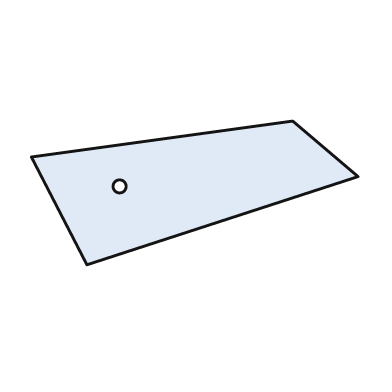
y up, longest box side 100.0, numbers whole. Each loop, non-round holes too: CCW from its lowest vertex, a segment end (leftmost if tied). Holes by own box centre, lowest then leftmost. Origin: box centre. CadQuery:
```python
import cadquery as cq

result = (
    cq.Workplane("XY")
    .moveTo(-33.0, -22.0)
    .lineTo(50.0, 5.0)
    .lineTo(30.0, 22.0)
    .lineTo(-50.0, 11.0)
    .close()
    .moveTo(-23.0, 2.0)
    .circle(2.0)
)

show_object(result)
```